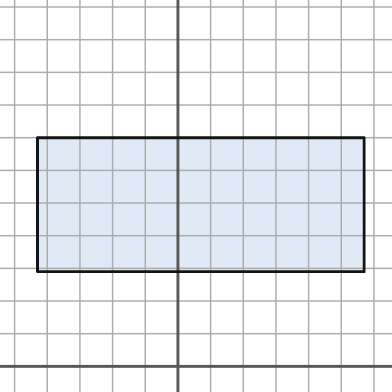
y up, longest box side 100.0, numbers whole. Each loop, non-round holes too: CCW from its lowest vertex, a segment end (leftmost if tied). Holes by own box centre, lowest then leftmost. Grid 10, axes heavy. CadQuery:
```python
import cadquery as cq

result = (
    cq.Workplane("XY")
    .moveTo(-43.0, 29.0)
    .lineTo(57.0, 29.0)
    .lineTo(57.0, 70.0)
    .lineTo(-43.0, 70.0)
    .close()
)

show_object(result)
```